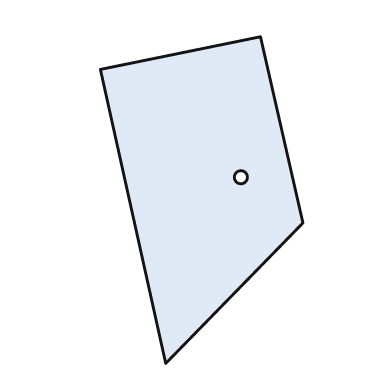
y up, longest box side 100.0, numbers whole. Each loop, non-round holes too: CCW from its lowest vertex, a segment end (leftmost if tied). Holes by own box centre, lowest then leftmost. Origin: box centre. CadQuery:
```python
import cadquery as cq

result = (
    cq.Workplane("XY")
    .moveTo(-11.0, -50.0)
    .lineTo(31.0, -7.0)
    .lineTo(18.0, 50.0)
    .lineTo(-31.0, 40.0)
    .close()
    .moveTo(12.0, 7.0)
    .circle(2.0)
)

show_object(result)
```